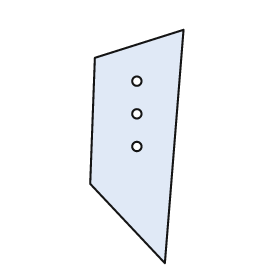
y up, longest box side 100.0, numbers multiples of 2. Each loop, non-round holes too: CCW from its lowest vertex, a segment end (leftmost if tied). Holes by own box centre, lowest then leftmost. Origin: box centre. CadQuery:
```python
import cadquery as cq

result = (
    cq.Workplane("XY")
    .moveTo(12.0, -50.0)
    .lineTo(20.0, 50.0)
    .lineTo(-18.0, 38.0)
    .lineTo(-20.0, -16.0)
    .close()
    .moveTo(0.0, 0.0)
    .circle(2.0)
    .moveTo(0.0, 14.0)
    .circle(2.0)
    .moveTo(0.0, 28.0)
    .circle(2.0)
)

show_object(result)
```